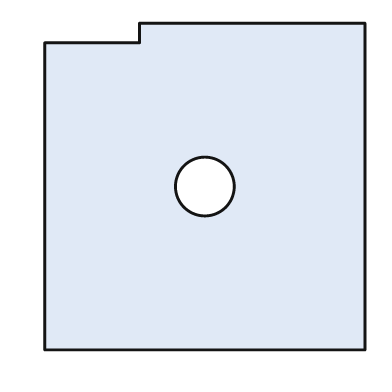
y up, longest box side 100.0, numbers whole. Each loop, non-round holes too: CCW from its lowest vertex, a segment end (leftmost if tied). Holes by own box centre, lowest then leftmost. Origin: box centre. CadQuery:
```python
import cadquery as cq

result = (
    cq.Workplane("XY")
    .moveTo(-49.0, -50.0)
    .lineTo(49.0, -50.0)
    .lineTo(49.0, 50.0)
    .lineTo(-20.0, 50.0)
    .lineTo(-20.0, 44.0)
    .lineTo(-49.0, 44.0)
    .close()
    .moveTo(0.0, 0.0)
    .circle(9.0)
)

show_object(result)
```